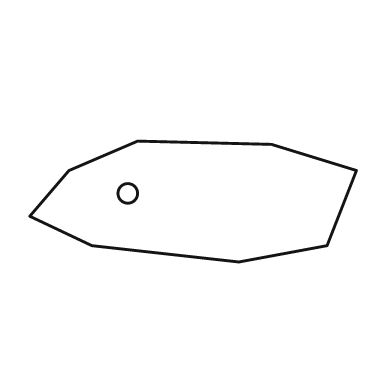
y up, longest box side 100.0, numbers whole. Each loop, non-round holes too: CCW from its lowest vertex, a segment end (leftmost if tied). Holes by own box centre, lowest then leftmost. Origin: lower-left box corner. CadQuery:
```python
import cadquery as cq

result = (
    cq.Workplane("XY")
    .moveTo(64.0, 0.0)
    .lineTo(91.0, 5.0)
    .lineTo(100.0, 28.0)
    .lineTo(74.0, 36.0)
    .lineTo(33.0, 37.0)
    .lineTo(12.0, 28.0)
    .lineTo(0.0, 14.0)
    .lineTo(19.0, 5.0)
    .close()
    .moveTo(30.0, 21.0)
    .circle(3.0)
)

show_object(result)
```